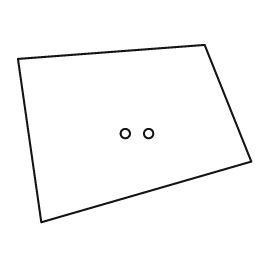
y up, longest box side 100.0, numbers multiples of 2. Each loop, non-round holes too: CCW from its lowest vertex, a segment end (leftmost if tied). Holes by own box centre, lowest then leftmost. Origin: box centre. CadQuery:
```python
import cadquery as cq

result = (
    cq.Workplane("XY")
    .moveTo(-40.0, -38.0)
    .lineTo(50.0, -12.0)
    .lineTo(30.0, 38.0)
    .lineTo(-50.0, 32.0)
    .close()
    .moveTo(-4.0, 0.0)
    .circle(2.0)
    .moveTo(6.0, 0.0)
    .circle(2.0)
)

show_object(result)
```